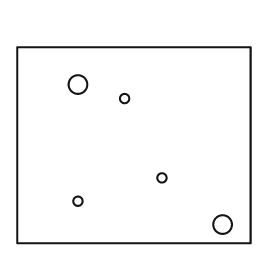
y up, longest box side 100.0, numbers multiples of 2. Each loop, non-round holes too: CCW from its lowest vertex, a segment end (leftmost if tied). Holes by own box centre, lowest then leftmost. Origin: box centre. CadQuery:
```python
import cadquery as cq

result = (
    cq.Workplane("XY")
    .moveTo(-50.0, -42.0)
    .lineTo(50.0, -42.0)
    .lineTo(50.0, 42.0)
    .lineTo(-50.0, 42.0)
    .close()
    .moveTo(38.0, -34.0)
    .circle(4.0)
    .moveTo(-24.0, -24.0)
    .circle(2.0)
    .moveTo(12.0, -14.0)
    .circle(2.0)
    .moveTo(-4.0, 20.0)
    .circle(2.0)
    .moveTo(-24.0, 26.0)
    .circle(4.0)
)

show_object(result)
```